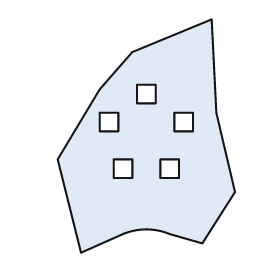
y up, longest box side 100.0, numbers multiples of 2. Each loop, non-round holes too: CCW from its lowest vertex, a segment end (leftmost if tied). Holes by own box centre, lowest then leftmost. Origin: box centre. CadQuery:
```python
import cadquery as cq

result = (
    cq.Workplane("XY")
    .moveTo(-28.0, -50.0)
    .lineTo(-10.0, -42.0)
    .threePointArc((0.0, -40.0), (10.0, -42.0))
    .lineTo(24.0, -46.0)
    .lineTo(38.0, -24.0)
    .lineTo(30.0, 10.0)
    .lineTo(28.0, 50.0)
    .lineTo(-6.0, 36.0)
    .lineTo(-20.0, 20.0)
    .lineTo(-38.0, -10.0)
    .close()
    .moveTo(-14.0, -18.0)
    .lineTo(-6.0, -18.0)
    .lineTo(-6.0, -10.0)
    .lineTo(-14.0, -10.0)
    .close()
    .moveTo(6.0, -18.0)
    .lineTo(14.0, -18.0)
    .lineTo(14.0, -10.0)
    .lineTo(6.0, -10.0)
    .close()
    .moveTo(-20.0, 2.0)
    .lineTo(-12.0, 2.0)
    .lineTo(-12.0, 10.0)
    .lineTo(-20.0, 10.0)
    .close()
    .moveTo(12.0, 2.0)
    .lineTo(20.0, 2.0)
    .lineTo(20.0, 10.0)
    .lineTo(12.0, 10.0)
    .close()
    .moveTo(-4.0, 14.0)
    .lineTo(4.0, 14.0)
    .lineTo(4.0, 22.0)
    .lineTo(-4.0, 22.0)
    .close()
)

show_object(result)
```